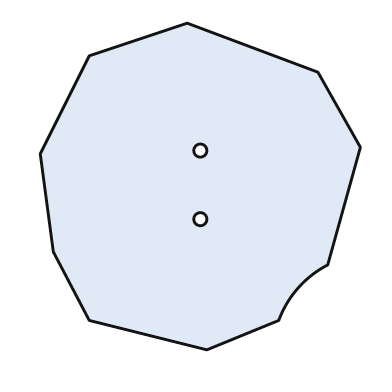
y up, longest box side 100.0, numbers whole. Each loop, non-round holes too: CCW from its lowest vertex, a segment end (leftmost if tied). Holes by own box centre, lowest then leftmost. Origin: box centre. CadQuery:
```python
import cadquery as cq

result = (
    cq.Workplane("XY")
    .moveTo(2.0, -50.0)
    .lineTo(24.0, -41.0)
    .threePointArc((30.0, -31.0), (39.0, -24.0))
    .lineTo(49.0, 12.0)
    .lineTo(36.0, 35.0)
    .lineTo(-4.0, 50.0)
    .lineTo(-34.0, 40.0)
    .lineTo(-49.0, 10.0)
    .lineTo(-45.0, -20.0)
    .lineTo(-34.0, -41.0)
    .close()
    .moveTo(0.0, -10.0)
    .circle(2.0)
    .moveTo(0.0, 11.0)
    .circle(2.0)
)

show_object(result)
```